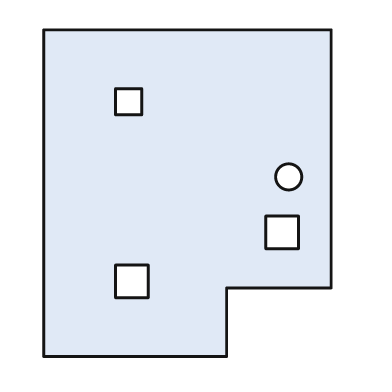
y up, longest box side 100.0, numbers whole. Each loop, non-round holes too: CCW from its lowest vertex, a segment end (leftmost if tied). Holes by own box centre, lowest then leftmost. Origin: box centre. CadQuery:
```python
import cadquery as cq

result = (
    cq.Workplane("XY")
    .moveTo(-44.0, -50.0)
    .lineTo(12.0, -50.0)
    .lineTo(12.0, -29.0)
    .lineTo(44.0, -29.0)
    .lineTo(44.0, 50.0)
    .lineTo(-44.0, 50.0)
    .close()
    .moveTo(-22.0, -32.0)
    .lineTo(-12.0, -32.0)
    .lineTo(-12.0, -22.0)
    .lineTo(-22.0, -22.0)
    .close()
    .moveTo(24.0, -17.0)
    .lineTo(34.0, -17.0)
    .lineTo(34.0, -7.0)
    .lineTo(24.0, -7.0)
    .close()
    .moveTo(31.0, 5.0)
    .circle(4.0)
    .moveTo(-22.0, 24.0)
    .lineTo(-14.0, 24.0)
    .lineTo(-14.0, 32.0)
    .lineTo(-22.0, 32.0)
    .close()
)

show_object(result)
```